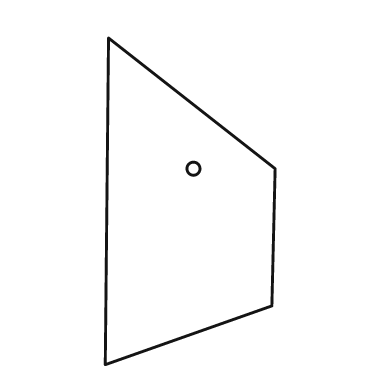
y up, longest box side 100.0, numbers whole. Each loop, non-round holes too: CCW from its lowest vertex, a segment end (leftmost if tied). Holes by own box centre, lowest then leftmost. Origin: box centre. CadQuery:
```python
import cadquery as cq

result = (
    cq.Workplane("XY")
    .moveTo(-26.0, -50.0)
    .lineTo(25.0, -32.0)
    .lineTo(26.0, 10.0)
    .lineTo(-25.0, 50.0)
    .close()
    .moveTo(1.0, 10.0)
    .circle(2.0)
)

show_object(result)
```